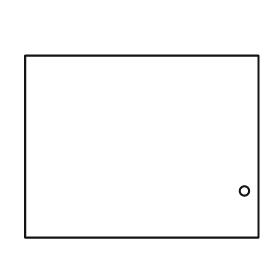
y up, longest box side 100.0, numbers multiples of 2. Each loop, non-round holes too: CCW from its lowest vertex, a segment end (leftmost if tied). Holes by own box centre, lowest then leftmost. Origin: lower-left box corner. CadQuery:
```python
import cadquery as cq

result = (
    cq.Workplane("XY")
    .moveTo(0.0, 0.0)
    .lineTo(100.0, 0.0)
    .lineTo(100.0, 78.0)
    .lineTo(0.0, 78.0)
    .close()
    .moveTo(94.0, 20.0)
    .circle(2.0)
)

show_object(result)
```